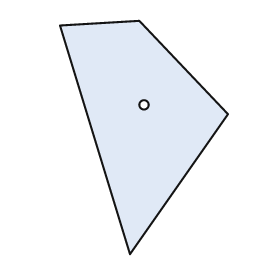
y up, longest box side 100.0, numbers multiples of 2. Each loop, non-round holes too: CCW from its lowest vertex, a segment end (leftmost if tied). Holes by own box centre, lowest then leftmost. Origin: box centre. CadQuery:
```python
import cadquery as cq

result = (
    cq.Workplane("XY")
    .moveTo(-6.0, -50.0)
    .lineTo(36.0, 10.0)
    .lineTo(-2.0, 50.0)
    .lineTo(-36.0, 48.0)
    .close()
    .moveTo(0.0, 14.0)
    .circle(2.0)
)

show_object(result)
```